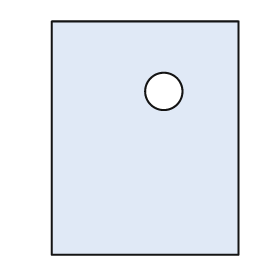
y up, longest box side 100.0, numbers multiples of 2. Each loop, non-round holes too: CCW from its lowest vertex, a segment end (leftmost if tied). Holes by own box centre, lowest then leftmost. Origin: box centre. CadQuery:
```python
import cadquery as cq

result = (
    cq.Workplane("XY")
    .moveTo(-40.0, -50.0)
    .lineTo(40.0, -50.0)
    .lineTo(40.0, 50.0)
    .lineTo(-40.0, 50.0)
    .close()
    .moveTo(8.0, 20.0)
    .circle(8.0)
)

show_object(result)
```